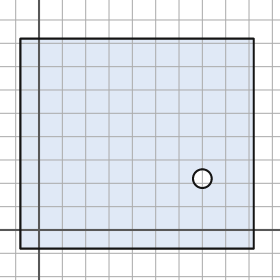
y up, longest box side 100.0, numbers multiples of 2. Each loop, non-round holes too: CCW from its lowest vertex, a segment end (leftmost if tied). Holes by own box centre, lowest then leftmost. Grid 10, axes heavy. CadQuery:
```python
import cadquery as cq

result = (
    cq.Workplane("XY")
    .moveTo(-8.0, -8.0)
    .lineTo(92.0, -8.0)
    .lineTo(92.0, 82.0)
    .lineTo(-8.0, 82.0)
    .close()
    .moveTo(70.0, 22.0)
    .circle(4.0)
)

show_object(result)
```